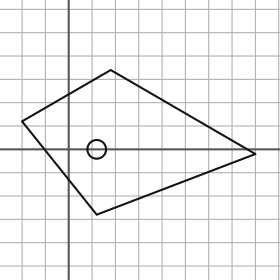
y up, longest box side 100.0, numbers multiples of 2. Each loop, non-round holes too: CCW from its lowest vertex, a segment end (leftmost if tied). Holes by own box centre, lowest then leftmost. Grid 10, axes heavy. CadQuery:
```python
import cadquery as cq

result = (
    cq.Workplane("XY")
    .moveTo(12.0, -28.0)
    .lineTo(80.0, -2.0)
    .lineTo(18.0, 34.0)
    .lineTo(-20.0, 12.0)
    .close()
    .moveTo(12.0, 0.0)
    .circle(4.0)
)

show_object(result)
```